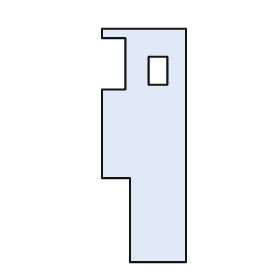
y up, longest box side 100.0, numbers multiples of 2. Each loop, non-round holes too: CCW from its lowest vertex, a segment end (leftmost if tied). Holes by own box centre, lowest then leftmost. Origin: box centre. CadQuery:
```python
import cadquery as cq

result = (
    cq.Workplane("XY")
    .moveTo(-6.0, -50.0)
    .lineTo(18.0, -50.0)
    .lineTo(18.0, 50.0)
    .lineTo(-18.0, 50.0)
    .lineTo(-18.0, 46.0)
    .lineTo(-8.0, 46.0)
    .lineTo(-8.0, 24.0)
    .lineTo(-18.0, 24.0)
    .lineTo(-18.0, -14.0)
    .lineTo(-6.0, -14.0)
    .close()
    .moveTo(2.0, 26.0)
    .lineTo(10.0, 26.0)
    .lineTo(10.0, 38.0)
    .lineTo(2.0, 38.0)
    .close()
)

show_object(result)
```